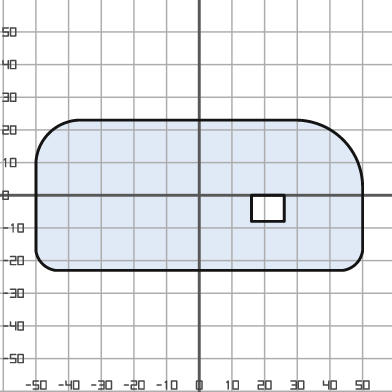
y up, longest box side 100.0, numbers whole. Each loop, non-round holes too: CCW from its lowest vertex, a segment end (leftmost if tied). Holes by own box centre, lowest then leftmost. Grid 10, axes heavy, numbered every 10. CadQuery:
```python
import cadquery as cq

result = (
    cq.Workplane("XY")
    .moveTo(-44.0, -23.0)
    .lineTo(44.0, -23.0)
    .threePointArc((48.0, -21.0), (50.0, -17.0))
    .lineTo(50.0, 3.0)
    .threePointArc((44.0, 17.0), (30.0, 23.0))
    .lineTo(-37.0, 23.0)
    .threePointArc((-46.0, 19.0), (-50.0, 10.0))
    .lineTo(-50.0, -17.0)
    .threePointArc((-48.0, -21.0), (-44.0, -23.0))
    .close()
    .moveTo(16.0, -8.0)
    .lineTo(26.0, -8.0)
    .lineTo(26.0, 0.0)
    .lineTo(16.0, 0.0)
    .close()
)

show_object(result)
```